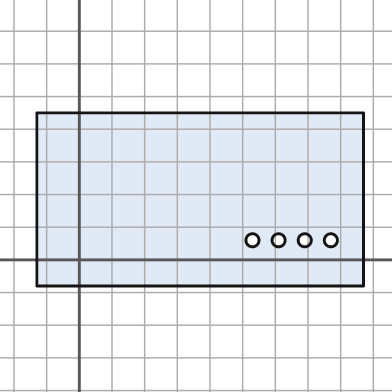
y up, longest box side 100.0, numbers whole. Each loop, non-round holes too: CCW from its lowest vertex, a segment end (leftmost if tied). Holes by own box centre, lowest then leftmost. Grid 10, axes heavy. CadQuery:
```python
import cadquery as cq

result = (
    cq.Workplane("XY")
    .moveTo(-13.0, -8.0)
    .lineTo(87.0, -8.0)
    .lineTo(87.0, 45.0)
    .lineTo(-13.0, 45.0)
    .close()
    .moveTo(53.0, 6.0)
    .circle(2.0)
    .moveTo(61.0, 6.0)
    .circle(2.0)
    .moveTo(69.0, 6.0)
    .circle(2.0)
    .moveTo(77.0, 6.0)
    .circle(2.0)
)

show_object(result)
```